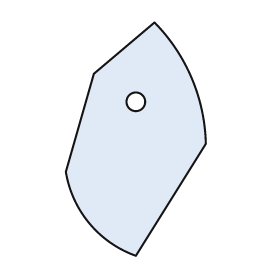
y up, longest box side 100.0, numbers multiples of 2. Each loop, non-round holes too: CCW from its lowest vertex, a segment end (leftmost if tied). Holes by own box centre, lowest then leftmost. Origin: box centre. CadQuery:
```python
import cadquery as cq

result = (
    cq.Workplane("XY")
    .moveTo(0.0, -50.0)
    .lineTo(30.0, -2.0)
    .threePointArc((24.0, 26.0), (8.0, 50.0))
    .lineTo(-18.0, 28.0)
    .lineTo(-30.0, -14.0)
    .threePointArc((-20.0, -36.0), (0.0, -50.0))
    .close()
    .moveTo(0.0, 16.0)
    .circle(4.0)
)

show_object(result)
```